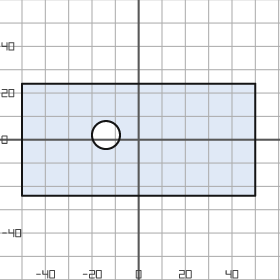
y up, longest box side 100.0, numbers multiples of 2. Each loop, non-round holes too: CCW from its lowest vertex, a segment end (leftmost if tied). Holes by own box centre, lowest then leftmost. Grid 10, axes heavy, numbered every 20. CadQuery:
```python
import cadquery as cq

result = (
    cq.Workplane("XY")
    .moveTo(-50.0, -24.0)
    .lineTo(50.0, -24.0)
    .lineTo(50.0, 24.0)
    .lineTo(-50.0, 24.0)
    .close()
    .moveTo(-14.0, 2.0)
    .circle(6.0)
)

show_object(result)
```